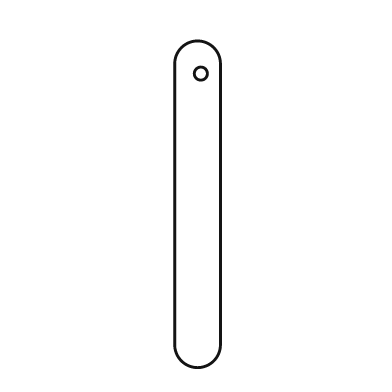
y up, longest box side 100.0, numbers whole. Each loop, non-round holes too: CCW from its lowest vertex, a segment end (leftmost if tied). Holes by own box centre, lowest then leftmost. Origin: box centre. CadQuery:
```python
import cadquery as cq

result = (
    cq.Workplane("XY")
    .moveTo(-7.0, -43.0)
    .threePointArc((0.0, -50.0), (7.0, -43.0))
    .lineTo(7.0, 43.0)
    .threePointArc((0.0, 50.0), (-7.0, 43.0))
    .close()
    .moveTo(1.0, 40.0)
    .circle(2.0)
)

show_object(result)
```